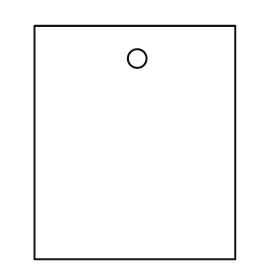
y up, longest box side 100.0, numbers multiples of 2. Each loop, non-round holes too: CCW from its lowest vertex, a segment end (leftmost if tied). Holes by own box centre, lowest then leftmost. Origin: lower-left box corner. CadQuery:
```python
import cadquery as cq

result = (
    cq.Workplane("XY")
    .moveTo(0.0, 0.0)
    .lineTo(86.0, 0.0)
    .lineTo(86.0, 100.0)
    .lineTo(0.0, 100.0)
    .close()
    .moveTo(44.0, 86.0)
    .circle(4.0)
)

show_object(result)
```